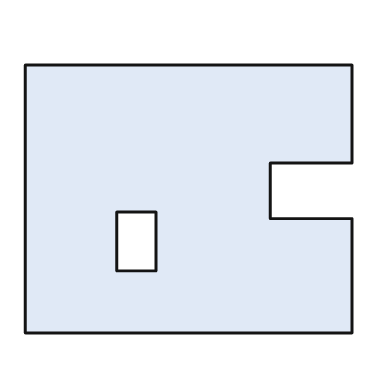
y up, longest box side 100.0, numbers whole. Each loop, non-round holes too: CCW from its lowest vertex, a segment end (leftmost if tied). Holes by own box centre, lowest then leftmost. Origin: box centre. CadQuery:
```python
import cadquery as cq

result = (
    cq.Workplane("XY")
    .moveTo(-50.0, -41.0)
    .lineTo(50.0, -41.0)
    .lineTo(50.0, -6.0)
    .lineTo(25.0, -6.0)
    .lineTo(25.0, 11.0)
    .lineTo(50.0, 11.0)
    .lineTo(50.0, 41.0)
    .lineTo(-50.0, 41.0)
    .close()
    .moveTo(-22.0, -22.0)
    .lineTo(-10.0, -22.0)
    .lineTo(-10.0, -4.0)
    .lineTo(-22.0, -4.0)
    .close()
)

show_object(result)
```